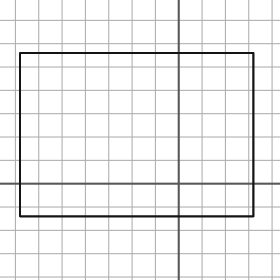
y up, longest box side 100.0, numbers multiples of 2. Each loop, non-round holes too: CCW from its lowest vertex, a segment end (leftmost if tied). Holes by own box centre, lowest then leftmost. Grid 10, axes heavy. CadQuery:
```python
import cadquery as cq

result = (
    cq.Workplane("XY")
    .moveTo(-68.0, -14.0)
    .lineTo(32.0, -14.0)
    .lineTo(32.0, 56.0)
    .lineTo(-68.0, 56.0)
    .close()
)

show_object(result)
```